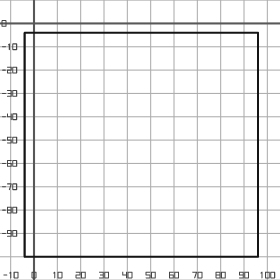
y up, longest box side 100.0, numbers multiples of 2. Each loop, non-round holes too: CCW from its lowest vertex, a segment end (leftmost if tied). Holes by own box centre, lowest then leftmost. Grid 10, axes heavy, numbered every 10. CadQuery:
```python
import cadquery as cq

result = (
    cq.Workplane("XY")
    .moveTo(-4.0, -100.0)
    .lineTo(96.0, -100.0)
    .lineTo(96.0, -4.0)
    .lineTo(-4.0, -4.0)
    .close()
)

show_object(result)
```